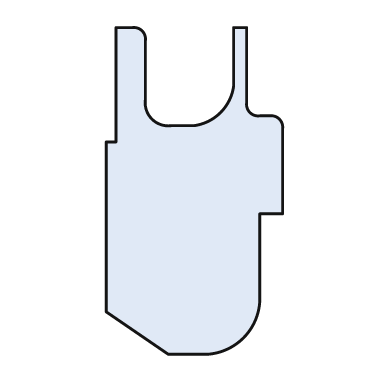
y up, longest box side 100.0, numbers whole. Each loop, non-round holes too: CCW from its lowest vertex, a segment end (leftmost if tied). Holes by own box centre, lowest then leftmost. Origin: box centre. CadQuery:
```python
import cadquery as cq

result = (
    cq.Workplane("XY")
    .moveTo(-8.0, -50.0)
    .lineTo(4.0, -50.0)
    .threePointArc((15.0, -45.0), (20.0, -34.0))
    .lineTo(20.0, -7.0)
    .lineTo(27.0, -7.0)
    .lineTo(27.0, 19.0)
    .threePointArc((26.0, 22.0), (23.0, 23.0))
    .lineTo(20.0, 23.0)
    .threePointArc((17.0, 24.0), (16.0, 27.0))
    .lineTo(16.0, 50.0)
    .lineTo(12.0, 50.0)
    .lineTo(12.0, 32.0)
    .threePointArc((8.0, 24.0), (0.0, 20.0))
    .lineTo(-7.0, 20.0)
    .threePointArc((-13.0, 22.0), (-15.0, 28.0))
    .lineTo(-15.0, 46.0)
    .threePointArc((-16.0, 49.0), (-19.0, 50.0))
    .lineTo(-24.0, 50.0)
    .lineTo(-24.0, 15.0)
    .lineTo(-27.0, 15.0)
    .lineTo(-27.0, -37.0)
    .close()
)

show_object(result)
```